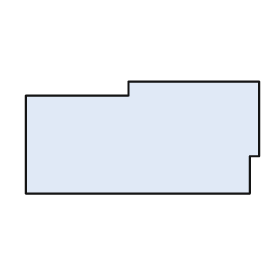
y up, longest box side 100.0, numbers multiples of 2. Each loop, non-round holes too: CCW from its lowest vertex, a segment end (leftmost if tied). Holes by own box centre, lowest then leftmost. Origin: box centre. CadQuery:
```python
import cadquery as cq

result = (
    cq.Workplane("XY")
    .moveTo(-50.0, -24.0)
    .lineTo(46.0, -24.0)
    .lineTo(46.0, -8.0)
    .lineTo(50.0, -8.0)
    .lineTo(50.0, 24.0)
    .lineTo(-6.0, 24.0)
    .lineTo(-6.0, 18.0)
    .lineTo(-50.0, 18.0)
    .close()
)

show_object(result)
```